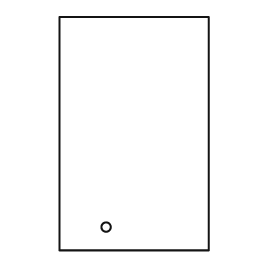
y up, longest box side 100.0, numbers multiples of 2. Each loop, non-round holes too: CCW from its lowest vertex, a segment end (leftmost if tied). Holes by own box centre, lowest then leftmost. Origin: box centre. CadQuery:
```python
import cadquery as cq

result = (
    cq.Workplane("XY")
    .moveTo(-32.0, -50.0)
    .lineTo(32.0, -50.0)
    .lineTo(32.0, 50.0)
    .lineTo(-32.0, 50.0)
    .close()
    .moveTo(-12.0, -40.0)
    .circle(2.0)
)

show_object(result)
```